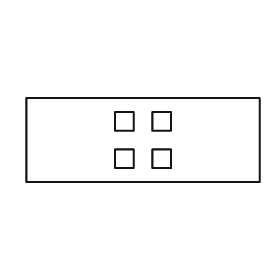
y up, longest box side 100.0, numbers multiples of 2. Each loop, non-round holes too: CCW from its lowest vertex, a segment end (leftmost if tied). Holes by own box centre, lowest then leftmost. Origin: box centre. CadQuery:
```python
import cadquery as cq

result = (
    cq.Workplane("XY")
    .moveTo(-50.0, -18.0)
    .lineTo(50.0, -18.0)
    .lineTo(50.0, 18.0)
    .lineTo(-50.0, 18.0)
    .close()
    .moveTo(-12.0, -12.0)
    .lineTo(-4.0, -12.0)
    .lineTo(-4.0, -4.0)
    .lineTo(-12.0, -4.0)
    .close()
    .moveTo(4.0, -12.0)
    .lineTo(12.0, -12.0)
    .lineTo(12.0, -4.0)
    .lineTo(4.0, -4.0)
    .close()
    .moveTo(-12.0, 4.0)
    .lineTo(-4.0, 4.0)
    .lineTo(-4.0, 12.0)
    .lineTo(-12.0, 12.0)
    .close()
    .moveTo(4.0, 4.0)
    .lineTo(12.0, 4.0)
    .lineTo(12.0, 12.0)
    .lineTo(4.0, 12.0)
    .close()
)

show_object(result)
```